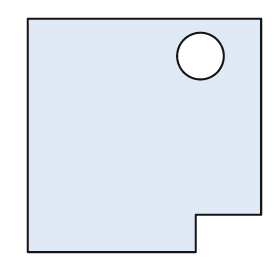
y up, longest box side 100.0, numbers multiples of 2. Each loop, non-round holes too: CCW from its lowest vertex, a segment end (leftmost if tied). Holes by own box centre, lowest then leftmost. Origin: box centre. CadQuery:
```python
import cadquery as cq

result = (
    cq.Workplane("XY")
    .moveTo(-50.0, -50.0)
    .lineTo(22.0, -50.0)
    .lineTo(22.0, -34.0)
    .lineTo(50.0, -34.0)
    .lineTo(50.0, 50.0)
    .lineTo(-50.0, 50.0)
    .close()
    .moveTo(24.0, 34.0)
    .circle(10.0)
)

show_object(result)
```